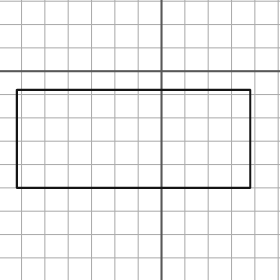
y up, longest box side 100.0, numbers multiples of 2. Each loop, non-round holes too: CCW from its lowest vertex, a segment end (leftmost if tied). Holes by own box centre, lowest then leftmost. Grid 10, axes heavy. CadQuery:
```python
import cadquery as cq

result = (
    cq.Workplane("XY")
    .moveTo(-62.0, -50.0)
    .lineTo(38.0, -50.0)
    .lineTo(38.0, -8.0)
    .lineTo(-62.0, -8.0)
    .close()
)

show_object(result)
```